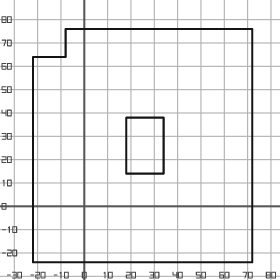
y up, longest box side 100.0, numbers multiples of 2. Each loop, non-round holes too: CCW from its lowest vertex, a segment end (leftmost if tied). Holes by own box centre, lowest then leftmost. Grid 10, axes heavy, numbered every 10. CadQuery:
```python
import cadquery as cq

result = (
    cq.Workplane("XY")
    .moveTo(-22.0, -24.0)
    .lineTo(72.0, -24.0)
    .lineTo(72.0, 76.0)
    .lineTo(-8.0, 76.0)
    .lineTo(-8.0, 64.0)
    .lineTo(-22.0, 64.0)
    .close()
    .moveTo(18.0, 14.0)
    .lineTo(34.0, 14.0)
    .lineTo(34.0, 38.0)
    .lineTo(18.0, 38.0)
    .close()
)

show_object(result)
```